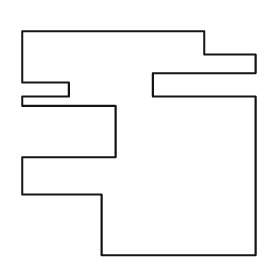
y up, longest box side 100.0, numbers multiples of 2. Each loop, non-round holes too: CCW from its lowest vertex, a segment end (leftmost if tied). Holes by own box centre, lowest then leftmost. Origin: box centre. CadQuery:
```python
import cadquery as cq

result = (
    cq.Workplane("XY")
    .moveTo(-16.0, -48.0)
    .lineTo(50.0, -48.0)
    .lineTo(50.0, 20.0)
    .lineTo(6.0, 20.0)
    .lineTo(6.0, 30.0)
    .lineTo(50.0, 30.0)
    .lineTo(50.0, 38.0)
    .lineTo(28.0, 38.0)
    .lineTo(28.0, 48.0)
    .lineTo(-50.0, 48.0)
    .lineTo(-50.0, 26.0)
    .lineTo(-30.0, 26.0)
    .lineTo(-30.0, 20.0)
    .lineTo(-50.0, 20.0)
    .lineTo(-50.0, 16.0)
    .lineTo(-10.0, 16.0)
    .lineTo(-10.0, -6.0)
    .lineTo(-50.0, -6.0)
    .lineTo(-50.0, -22.0)
    .lineTo(-16.0, -22.0)
    .close()
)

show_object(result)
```